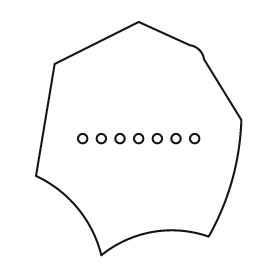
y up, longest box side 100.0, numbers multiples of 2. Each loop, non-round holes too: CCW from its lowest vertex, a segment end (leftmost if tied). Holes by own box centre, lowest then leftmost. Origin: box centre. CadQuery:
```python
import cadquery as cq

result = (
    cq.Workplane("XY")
    .moveTo(-16.0, -50.0)
    .threePointArc((6.0, -40.0), (30.0, -42.0))
    .threePointArc((40.0, -18.0), (44.0, 8.0))
    .lineTo(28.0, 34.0)
    .threePointArc((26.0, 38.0), (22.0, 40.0))
    .lineTo(0.0, 50.0)
    .lineTo(-36.0, 32.0)
    .lineTo(-44.0, -16.0)
    .threePointArc((-26.0, -30.0), (-16.0, -50.0))
    .close()
    .moveTo(-24.0, 0.0)
    .circle(2.0)
    .moveTo(-16.0, 0.0)
    .circle(2.0)
    .moveTo(-8.0, 0.0)
    .circle(2.0)
    .moveTo(0.0, 0.0)
    .circle(2.0)
    .moveTo(8.0, 0.0)
    .circle(2.0)
    .moveTo(16.0, 0.0)
    .circle(2.0)
    .moveTo(24.0, 0.0)
    .circle(2.0)
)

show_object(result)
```